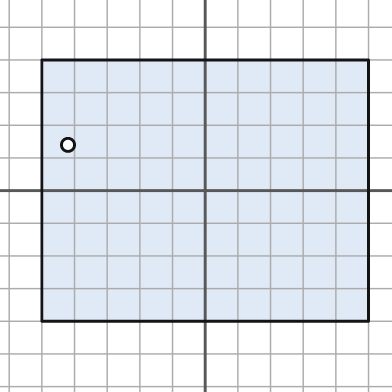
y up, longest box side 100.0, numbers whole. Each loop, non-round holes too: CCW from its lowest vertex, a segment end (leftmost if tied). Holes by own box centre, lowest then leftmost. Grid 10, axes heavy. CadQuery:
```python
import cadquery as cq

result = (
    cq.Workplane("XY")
    .moveTo(-50.0, -40.0)
    .lineTo(50.0, -40.0)
    .lineTo(50.0, 40.0)
    .lineTo(-50.0, 40.0)
    .close()
    .moveTo(-42.0, 14.0)
    .circle(2.0)
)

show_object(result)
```